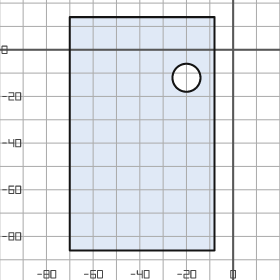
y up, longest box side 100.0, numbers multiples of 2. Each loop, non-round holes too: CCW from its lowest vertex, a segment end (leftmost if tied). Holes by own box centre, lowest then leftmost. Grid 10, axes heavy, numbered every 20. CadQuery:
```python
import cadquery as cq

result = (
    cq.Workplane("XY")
    .moveTo(-70.0, -86.0)
    .lineTo(-8.0, -86.0)
    .lineTo(-8.0, 14.0)
    .lineTo(-70.0, 14.0)
    .close()
    .moveTo(-20.0, -12.0)
    .circle(6.0)
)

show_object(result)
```